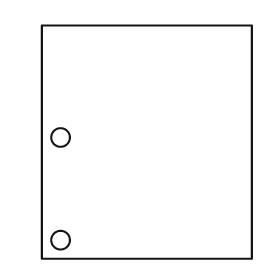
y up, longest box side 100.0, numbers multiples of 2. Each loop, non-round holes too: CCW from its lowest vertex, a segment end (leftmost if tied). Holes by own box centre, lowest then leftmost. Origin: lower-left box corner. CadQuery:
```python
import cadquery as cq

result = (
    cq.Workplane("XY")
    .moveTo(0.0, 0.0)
    .lineTo(90.0, 0.0)
    .lineTo(90.0, 100.0)
    .lineTo(0.0, 100.0)
    .close()
    .moveTo(8.0, 8.0)
    .circle(4.0)
    .moveTo(8.0, 52.0)
    .circle(4.0)
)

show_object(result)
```